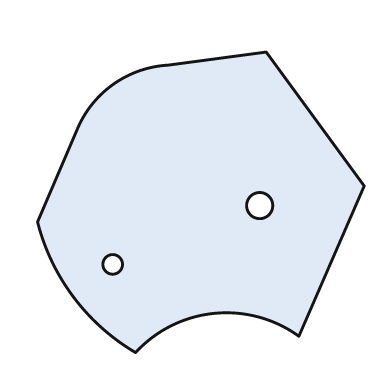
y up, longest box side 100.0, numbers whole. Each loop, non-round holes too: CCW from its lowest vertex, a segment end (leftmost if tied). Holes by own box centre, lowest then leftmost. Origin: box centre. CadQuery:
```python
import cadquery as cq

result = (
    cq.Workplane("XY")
    .moveTo(-20.0, -46.0)
    .threePointArc((4.0, -34.0), (30.0, -41.0))
    .lineTo(50.0, 5.0)
    .lineTo(20.0, 46.0)
    .lineTo(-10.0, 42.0)
    .threePointArc((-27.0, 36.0), (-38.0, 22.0))
    .lineTo(-50.0, -6.0)
    .threePointArc((-39.0, -29.0), (-20.0, -46.0))
    .close()
    .moveTo(-27.0, -19.0)
    .circle(3.0)
    .moveTo(18.0, -1.0)
    .circle(4.0)
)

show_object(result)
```